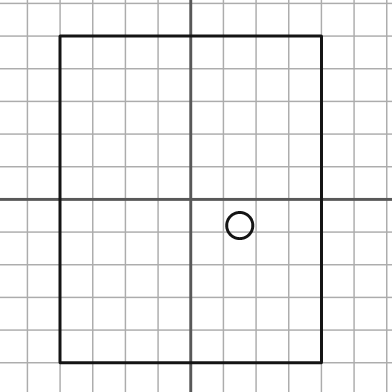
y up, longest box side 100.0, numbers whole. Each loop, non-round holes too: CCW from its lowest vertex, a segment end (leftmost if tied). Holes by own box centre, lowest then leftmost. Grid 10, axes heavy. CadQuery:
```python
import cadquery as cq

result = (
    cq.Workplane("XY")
    .moveTo(-40.0, -50.0)
    .lineTo(40.0, -50.0)
    .lineTo(40.0, 50.0)
    .lineTo(-40.0, 50.0)
    .close()
    .moveTo(15.0, -8.0)
    .circle(4.0)
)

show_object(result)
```